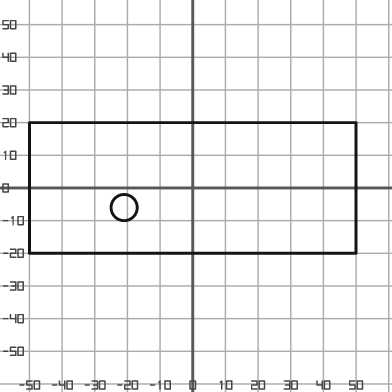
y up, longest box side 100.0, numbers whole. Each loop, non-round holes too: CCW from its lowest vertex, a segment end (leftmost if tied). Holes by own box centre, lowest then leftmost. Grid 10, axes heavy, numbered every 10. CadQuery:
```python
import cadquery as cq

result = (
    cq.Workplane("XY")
    .moveTo(-50.0, -20.0)
    .lineTo(50.0, -20.0)
    .lineTo(50.0, 20.0)
    .lineTo(-50.0, 20.0)
    .close()
    .moveTo(-21.0, -6.0)
    .circle(4.0)
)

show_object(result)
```